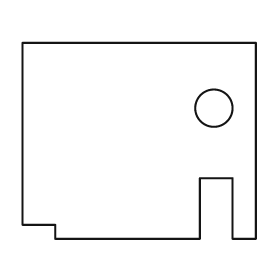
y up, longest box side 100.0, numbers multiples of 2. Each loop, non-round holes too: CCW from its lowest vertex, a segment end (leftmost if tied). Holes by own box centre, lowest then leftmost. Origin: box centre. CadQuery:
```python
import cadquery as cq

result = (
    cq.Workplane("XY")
    .moveTo(-36.0, -42.0)
    .lineTo(26.0, -42.0)
    .lineTo(26.0, -16.0)
    .lineTo(40.0, -16.0)
    .lineTo(40.0, -42.0)
    .lineTo(50.0, -42.0)
    .lineTo(50.0, 42.0)
    .lineTo(-50.0, 42.0)
    .lineTo(-50.0, -36.0)
    .lineTo(-36.0, -36.0)
    .close()
    .moveTo(32.0, 14.0)
    .circle(8.0)
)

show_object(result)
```